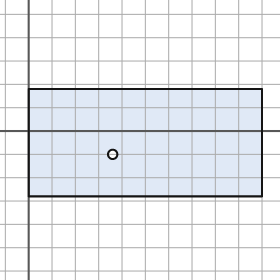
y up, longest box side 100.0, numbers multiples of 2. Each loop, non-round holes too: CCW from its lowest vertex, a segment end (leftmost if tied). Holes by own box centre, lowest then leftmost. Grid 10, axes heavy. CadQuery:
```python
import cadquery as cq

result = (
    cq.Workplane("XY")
    .moveTo(0.0, -28.0)
    .lineTo(100.0, -28.0)
    .lineTo(100.0, 18.0)
    .lineTo(0.0, 18.0)
    .close()
    .moveTo(36.0, -10.0)
    .circle(2.0)
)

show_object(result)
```